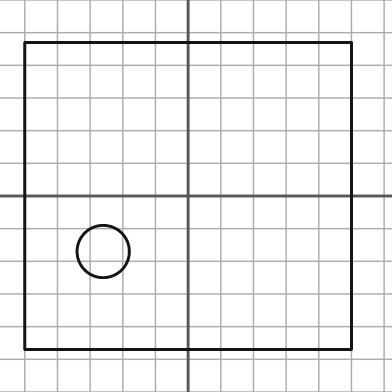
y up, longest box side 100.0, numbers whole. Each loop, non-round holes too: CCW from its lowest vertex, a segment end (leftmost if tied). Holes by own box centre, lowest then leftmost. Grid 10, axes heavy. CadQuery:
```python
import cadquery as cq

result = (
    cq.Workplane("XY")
    .moveTo(-50.0, -47.0)
    .lineTo(50.0, -47.0)
    .lineTo(50.0, 47.0)
    .lineTo(-50.0, 47.0)
    .close()
    .moveTo(-26.0, -17.0)
    .circle(8.0)
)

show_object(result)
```